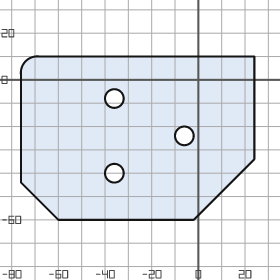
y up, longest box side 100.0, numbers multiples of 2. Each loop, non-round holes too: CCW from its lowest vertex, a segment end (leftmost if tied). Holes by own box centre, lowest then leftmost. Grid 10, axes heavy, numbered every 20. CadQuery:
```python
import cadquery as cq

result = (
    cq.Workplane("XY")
    .moveTo(-60.0, -60.0)
    .lineTo(-2.0, -60.0)
    .lineTo(24.0, -34.0)
    .lineTo(24.0, 10.0)
    .lineTo(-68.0, 10.0)
    .threePointArc((-74.0, 8.0), (-76.0, 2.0))
    .lineTo(-76.0, -44.0)
    .close()
    .moveTo(-36.0, -40.0)
    .circle(4.0)
    .moveTo(-6.0, -24.0)
    .circle(4.0)
    .moveTo(-36.0, -8.0)
    .circle(4.0)
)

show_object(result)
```